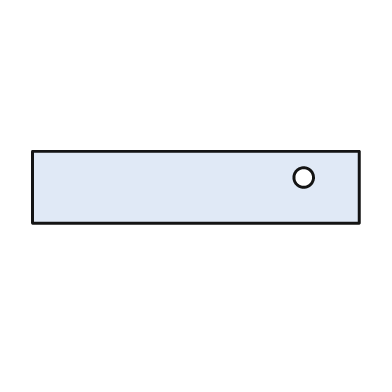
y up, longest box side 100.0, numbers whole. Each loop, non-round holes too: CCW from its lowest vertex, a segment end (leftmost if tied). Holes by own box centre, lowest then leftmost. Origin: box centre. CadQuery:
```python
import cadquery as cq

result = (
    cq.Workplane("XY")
    .moveTo(-50.0, -11.0)
    .lineTo(50.0, -11.0)
    .lineTo(50.0, 11.0)
    .lineTo(-50.0, 11.0)
    .close()
    .moveTo(33.0, 3.0)
    .circle(3.0)
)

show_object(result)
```